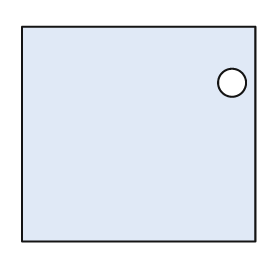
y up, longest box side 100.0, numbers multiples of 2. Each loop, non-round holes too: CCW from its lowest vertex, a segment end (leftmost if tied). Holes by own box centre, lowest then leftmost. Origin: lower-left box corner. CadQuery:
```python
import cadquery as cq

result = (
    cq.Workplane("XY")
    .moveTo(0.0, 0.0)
    .lineTo(100.0, 0.0)
    .lineTo(100.0, 92.0)
    .lineTo(0.0, 92.0)
    .close()
    .moveTo(90.0, 68.0)
    .circle(6.0)
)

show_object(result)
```